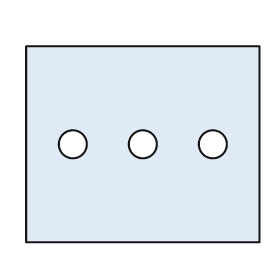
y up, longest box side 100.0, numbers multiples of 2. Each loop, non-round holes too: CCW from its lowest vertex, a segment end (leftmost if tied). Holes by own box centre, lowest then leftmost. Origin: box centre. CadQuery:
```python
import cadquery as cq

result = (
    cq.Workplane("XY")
    .moveTo(-50.0, -42.0)
    .lineTo(50.0, -42.0)
    .lineTo(50.0, 42.0)
    .lineTo(-50.0, 42.0)
    .close()
    .moveTo(-30.0, 0.0)
    .circle(6.0)
    .moveTo(0.0, 0.0)
    .circle(6.0)
    .moveTo(30.0, 0.0)
    .circle(6.0)
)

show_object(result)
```